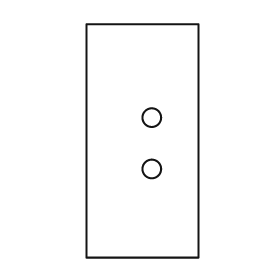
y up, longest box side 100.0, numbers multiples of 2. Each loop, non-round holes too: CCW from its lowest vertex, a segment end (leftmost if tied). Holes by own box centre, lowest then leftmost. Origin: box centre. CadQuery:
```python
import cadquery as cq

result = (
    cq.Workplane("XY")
    .moveTo(-24.0, -50.0)
    .lineTo(24.0, -50.0)
    .lineTo(24.0, 50.0)
    .lineTo(-24.0, 50.0)
    .close()
    .moveTo(4.0, -12.0)
    .circle(4.0)
    .moveTo(4.0, 10.0)
    .circle(4.0)
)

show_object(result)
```